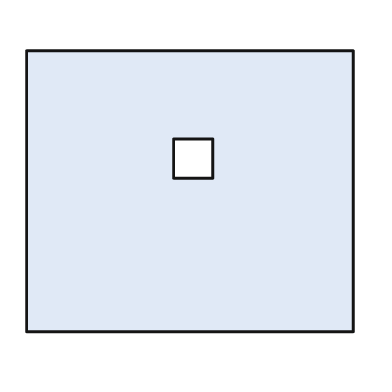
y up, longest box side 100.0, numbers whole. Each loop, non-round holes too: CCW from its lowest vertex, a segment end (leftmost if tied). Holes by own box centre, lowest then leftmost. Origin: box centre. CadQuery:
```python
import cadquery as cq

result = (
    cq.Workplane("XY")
    .moveTo(-50.0, -43.0)
    .lineTo(50.0, -43.0)
    .lineTo(50.0, 43.0)
    .lineTo(-50.0, 43.0)
    .close()
    .moveTo(-5.0, 4.0)
    .lineTo(7.0, 4.0)
    .lineTo(7.0, 16.0)
    .lineTo(-5.0, 16.0)
    .close()
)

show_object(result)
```